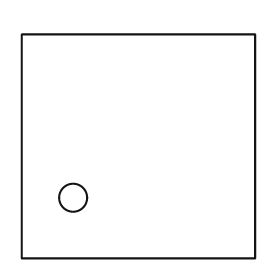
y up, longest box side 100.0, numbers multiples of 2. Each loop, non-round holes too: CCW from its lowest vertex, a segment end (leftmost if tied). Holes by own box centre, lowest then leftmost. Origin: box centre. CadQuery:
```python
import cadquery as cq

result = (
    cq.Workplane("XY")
    .moveTo(-50.0, -48.0)
    .lineTo(50.0, -48.0)
    .lineTo(50.0, 48.0)
    .lineTo(-50.0, 48.0)
    .close()
    .moveTo(-28.0, -22.0)
    .circle(6.0)
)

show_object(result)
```